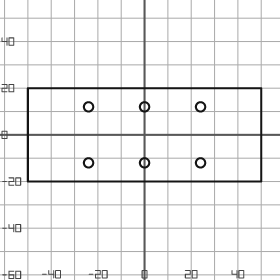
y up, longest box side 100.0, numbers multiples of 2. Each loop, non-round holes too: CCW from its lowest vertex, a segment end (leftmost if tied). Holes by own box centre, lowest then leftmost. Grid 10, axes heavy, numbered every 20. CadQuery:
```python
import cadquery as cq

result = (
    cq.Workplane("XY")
    .moveTo(-50.0, -20.0)
    .lineTo(50.0, -20.0)
    .lineTo(50.0, 20.0)
    .lineTo(-50.0, 20.0)
    .close()
    .moveTo(-24.0, -12.0)
    .circle(2.0)
    .moveTo(0.0, -12.0)
    .circle(2.0)
    .moveTo(24.0, -12.0)
    .circle(2.0)
    .moveTo(-24.0, 12.0)
    .circle(2.0)
    .moveTo(0.0, 12.0)
    .circle(2.0)
    .moveTo(24.0, 12.0)
    .circle(2.0)
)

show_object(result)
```